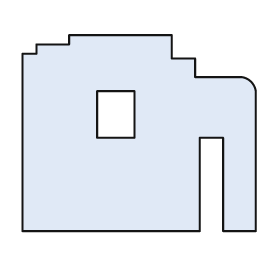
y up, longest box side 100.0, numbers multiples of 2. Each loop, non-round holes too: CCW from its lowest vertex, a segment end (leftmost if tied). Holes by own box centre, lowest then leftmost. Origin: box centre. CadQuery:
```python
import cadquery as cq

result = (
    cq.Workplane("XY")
    .moveTo(-50.0, -42.0)
    .lineTo(26.0, -42.0)
    .lineTo(26.0, -2.0)
    .lineTo(36.0, -2.0)
    .lineTo(36.0, -42.0)
    .lineTo(50.0, -42.0)
    .lineTo(50.0, 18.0)
    .threePointArc((48.0, 22.0), (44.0, 24.0))
    .lineTo(24.0, 24.0)
    .lineTo(24.0, 32.0)
    .lineTo(14.0, 32.0)
    .lineTo(14.0, 42.0)
    .lineTo(-30.0, 42.0)
    .lineTo(-30.0, 38.0)
    .lineTo(-44.0, 38.0)
    .lineTo(-44.0, 34.0)
    .lineTo(-50.0, 34.0)
    .close()
    .moveTo(-18.0, -2.0)
    .lineTo(-2.0, -2.0)
    .lineTo(-2.0, 18.0)
    .lineTo(-18.0, 18.0)
    .close()
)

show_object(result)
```